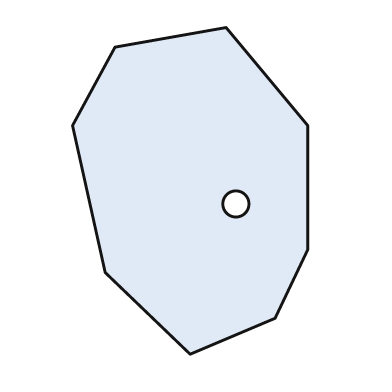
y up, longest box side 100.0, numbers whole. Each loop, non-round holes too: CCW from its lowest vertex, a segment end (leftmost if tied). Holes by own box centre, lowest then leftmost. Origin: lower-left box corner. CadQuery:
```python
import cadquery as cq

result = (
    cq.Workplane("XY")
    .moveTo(36.0, 0.0)
    .lineTo(62.0, 11.0)
    .lineTo(72.0, 32.0)
    .lineTo(72.0, 70.0)
    .lineTo(47.0, 100.0)
    .lineTo(13.0, 94.0)
    .lineTo(0.0, 70.0)
    .lineTo(10.0, 25.0)
    .close()
    .moveTo(50.0, 46.0)
    .circle(4.0)
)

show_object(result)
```